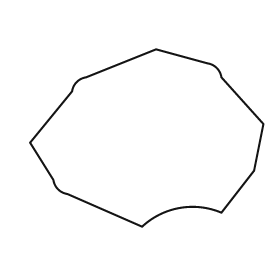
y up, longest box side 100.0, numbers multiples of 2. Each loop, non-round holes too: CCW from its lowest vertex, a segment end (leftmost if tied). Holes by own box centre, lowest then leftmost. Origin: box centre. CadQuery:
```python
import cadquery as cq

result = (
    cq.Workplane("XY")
    .moveTo(-2.0, -38.0)
    .threePointArc((14.0, -30.0), (32.0, -32.0))
    .lineTo(46.0, -14.0)
    .lineTo(50.0, 6.0)
    .lineTo(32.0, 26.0)
    .threePointArc((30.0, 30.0), (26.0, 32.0))
    .lineTo(4.0, 38.0)
    .lineTo(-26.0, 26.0)
    .threePointArc((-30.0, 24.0), (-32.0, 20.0))
    .lineTo(-50.0, -2.0)
    .lineTo(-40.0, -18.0)
    .threePointArc((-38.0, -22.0), (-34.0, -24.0))
    .close()
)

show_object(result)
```